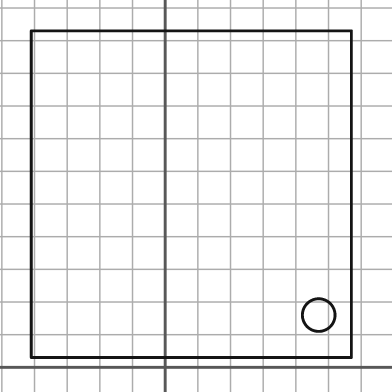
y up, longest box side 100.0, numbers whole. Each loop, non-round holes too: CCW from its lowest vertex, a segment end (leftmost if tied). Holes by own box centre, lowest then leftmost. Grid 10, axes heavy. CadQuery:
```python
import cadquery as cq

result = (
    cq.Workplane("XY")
    .moveTo(-41.0, 3.0)
    .lineTo(57.0, 3.0)
    .lineTo(57.0, 103.0)
    .lineTo(-41.0, 103.0)
    .close()
    .moveTo(47.0, 16.0)
    .circle(5.0)
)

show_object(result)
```